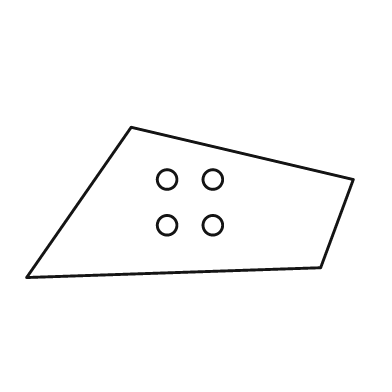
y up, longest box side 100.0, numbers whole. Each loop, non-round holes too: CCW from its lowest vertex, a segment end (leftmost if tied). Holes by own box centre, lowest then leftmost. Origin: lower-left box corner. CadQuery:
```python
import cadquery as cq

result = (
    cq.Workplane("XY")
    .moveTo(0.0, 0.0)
    .lineTo(90.0, 3.0)
    .lineTo(100.0, 30.0)
    .lineTo(32.0, 46.0)
    .close()
    .moveTo(43.0, 16.0)
    .circle(3.0)
    .moveTo(57.0, 16.0)
    .circle(3.0)
    .moveTo(43.0, 30.0)
    .circle(3.0)
    .moveTo(57.0, 30.0)
    .circle(3.0)
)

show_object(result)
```